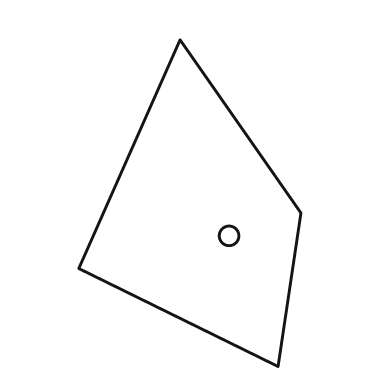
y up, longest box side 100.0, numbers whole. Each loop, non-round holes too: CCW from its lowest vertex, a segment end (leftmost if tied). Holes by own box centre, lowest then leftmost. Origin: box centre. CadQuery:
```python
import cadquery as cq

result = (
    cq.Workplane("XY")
    .moveTo(27.0, -50.0)
    .lineTo(34.0, -3.0)
    .lineTo(-3.0, 50.0)
    .lineTo(-34.0, -20.0)
    .close()
    .moveTo(12.0, -10.0)
    .circle(3.0)
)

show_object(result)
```